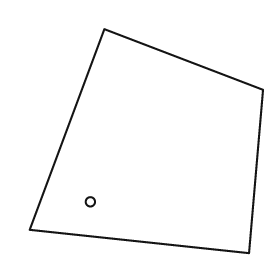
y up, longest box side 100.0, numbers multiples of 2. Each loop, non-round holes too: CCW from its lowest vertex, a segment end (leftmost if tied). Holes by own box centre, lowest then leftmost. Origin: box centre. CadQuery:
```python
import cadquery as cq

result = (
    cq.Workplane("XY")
    .moveTo(44.0, -48.0)
    .lineTo(50.0, 22.0)
    .lineTo(-18.0, 48.0)
    .lineTo(-50.0, -38.0)
    .close()
    .moveTo(-24.0, -26.0)
    .circle(2.0)
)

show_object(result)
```